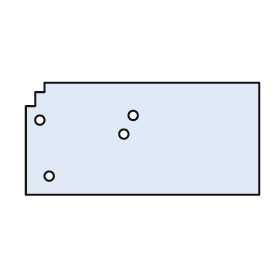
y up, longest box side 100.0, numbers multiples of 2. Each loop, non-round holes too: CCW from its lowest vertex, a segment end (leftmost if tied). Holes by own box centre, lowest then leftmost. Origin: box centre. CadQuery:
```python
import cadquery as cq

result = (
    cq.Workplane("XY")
    .moveTo(-50.0, -24.0)
    .lineTo(50.0, -24.0)
    .lineTo(50.0, 24.0)
    .lineTo(-42.0, 24.0)
    .lineTo(-42.0, 20.0)
    .lineTo(-46.0, 20.0)
    .lineTo(-46.0, 14.0)
    .lineTo(-50.0, 14.0)
    .close()
    .moveTo(-40.0, -16.0)
    .circle(2.0)
    .moveTo(-8.0, 2.0)
    .circle(2.0)
    .moveTo(-44.0, 8.0)
    .circle(2.0)
    .moveTo(-4.0, 10.0)
    .circle(2.0)
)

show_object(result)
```